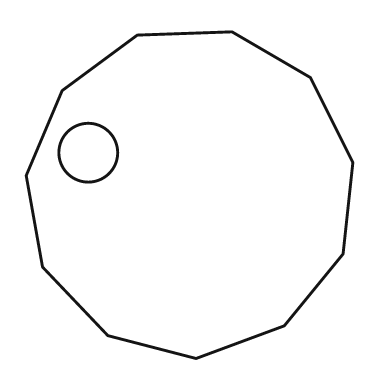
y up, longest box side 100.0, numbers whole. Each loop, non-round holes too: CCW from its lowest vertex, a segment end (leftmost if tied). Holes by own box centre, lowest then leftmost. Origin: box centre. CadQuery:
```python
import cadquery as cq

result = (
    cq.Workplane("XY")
    .moveTo(2.0, -50.0)
    .lineTo(29.0, -40.0)
    .lineTo(47.0, -18.0)
    .lineTo(50.0, 10.0)
    .lineTo(37.0, 36.0)
    .lineTo(13.0, 50.0)
    .lineTo(-16.0, 49.0)
    .lineTo(-39.0, 32.0)
    .lineTo(-50.0, 6.0)
    .lineTo(-45.0, -22.0)
    .lineTo(-25.0, -43.0)
    .close()
    .moveTo(-31.0, 13.0)
    .circle(9.0)
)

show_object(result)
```